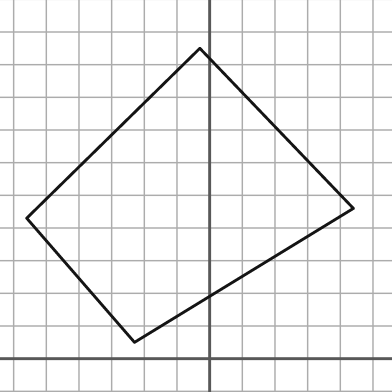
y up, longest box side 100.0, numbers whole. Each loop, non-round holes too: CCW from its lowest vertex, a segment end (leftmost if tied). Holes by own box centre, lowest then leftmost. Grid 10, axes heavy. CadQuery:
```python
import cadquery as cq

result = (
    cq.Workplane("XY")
    .moveTo(-23.0, 5.0)
    .lineTo(44.0, 46.0)
    .lineTo(-3.0, 95.0)
    .lineTo(-56.0, 43.0)
    .close()
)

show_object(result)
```